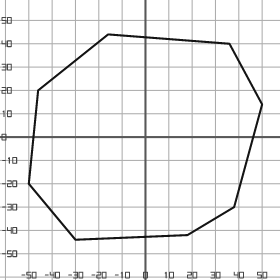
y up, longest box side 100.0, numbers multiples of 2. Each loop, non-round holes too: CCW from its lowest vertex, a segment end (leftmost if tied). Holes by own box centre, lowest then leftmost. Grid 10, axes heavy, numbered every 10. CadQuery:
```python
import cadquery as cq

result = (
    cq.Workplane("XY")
    .moveTo(-30.0, -44.0)
    .lineTo(18.0, -42.0)
    .lineTo(38.0, -30.0)
    .lineTo(50.0, 14.0)
    .lineTo(36.0, 40.0)
    .lineTo(-16.0, 44.0)
    .lineTo(-46.0, 20.0)
    .lineTo(-50.0, -20.0)
    .close()
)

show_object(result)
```